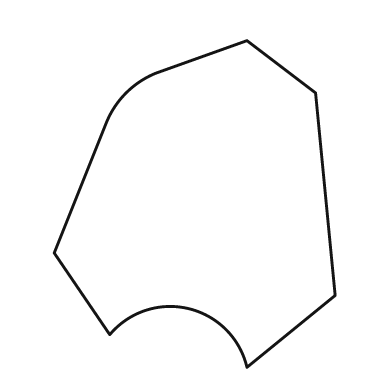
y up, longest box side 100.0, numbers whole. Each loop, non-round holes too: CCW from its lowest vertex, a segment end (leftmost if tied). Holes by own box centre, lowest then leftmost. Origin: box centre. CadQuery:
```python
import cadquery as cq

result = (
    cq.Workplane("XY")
    .moveTo(16.0, -50.0)
    .lineTo(43.0, -28.0)
    .lineTo(37.0, 34.0)
    .lineTo(16.0, 50.0)
    .lineTo(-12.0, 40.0)
    .threePointArc((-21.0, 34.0), (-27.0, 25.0))
    .lineTo(-43.0, -15.0)
    .lineTo(-26.0, -40.0)
    .threePointArc((-2.0, -32.0), (16.0, -50.0))
    .close()
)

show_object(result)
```